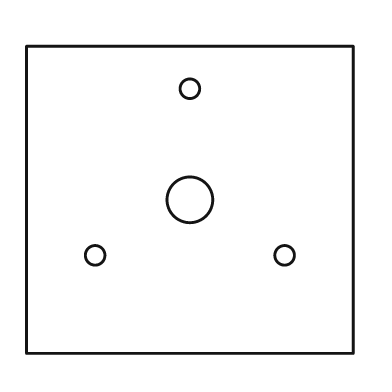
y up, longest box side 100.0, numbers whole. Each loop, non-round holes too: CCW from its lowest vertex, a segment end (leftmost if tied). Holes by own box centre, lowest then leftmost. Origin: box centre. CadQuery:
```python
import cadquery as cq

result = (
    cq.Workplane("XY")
    .moveTo(-50.0, -47.0)
    .lineTo(50.0, -47.0)
    .lineTo(50.0, 47.0)
    .lineTo(-50.0, 47.0)
    .close()
    .moveTo(-29.0, -17.0)
    .circle(3.0)
    .moveTo(29.0, -17.0)
    .circle(3.0)
    .moveTo(0.0, 0.0)
    .circle(7.0)
    .moveTo(0.0, 34.0)
    .circle(3.0)
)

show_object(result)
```